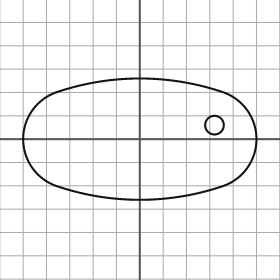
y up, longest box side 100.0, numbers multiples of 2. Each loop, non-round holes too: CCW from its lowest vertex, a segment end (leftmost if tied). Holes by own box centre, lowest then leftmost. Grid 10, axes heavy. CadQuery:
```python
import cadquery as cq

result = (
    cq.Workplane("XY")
    .moveTo(-36.0, -20.0)
    .threePointArc((0.0, -26.0), (36.0, -20.0))
    .threePointArc((50.0, 0.0), (36.0, 20.0))
    .threePointArc((0.0, 26.0), (-36.0, 20.0))
    .threePointArc((-50.0, 0.0), (-36.0, -20.0))
    .close()
    .moveTo(32.0, 6.0)
    .circle(4.0)
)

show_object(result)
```